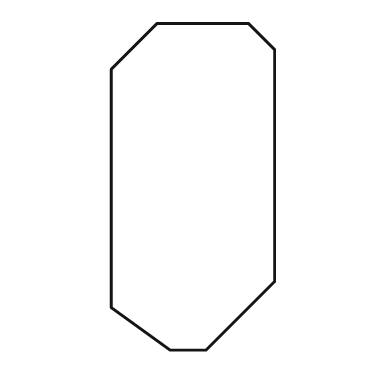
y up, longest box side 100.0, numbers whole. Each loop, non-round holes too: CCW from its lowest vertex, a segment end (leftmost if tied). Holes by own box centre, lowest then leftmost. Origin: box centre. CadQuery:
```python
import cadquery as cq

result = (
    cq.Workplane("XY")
    .moveTo(-7.0, -50.0)
    .lineTo(4.0, -50.0)
    .lineTo(25.0, -29.0)
    .lineTo(25.0, 42.0)
    .lineTo(17.0, 50.0)
    .lineTo(-11.0, 50.0)
    .lineTo(-25.0, 36.0)
    .lineTo(-25.0, -37.0)
    .close()
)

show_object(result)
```